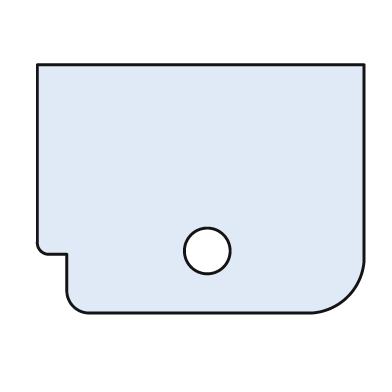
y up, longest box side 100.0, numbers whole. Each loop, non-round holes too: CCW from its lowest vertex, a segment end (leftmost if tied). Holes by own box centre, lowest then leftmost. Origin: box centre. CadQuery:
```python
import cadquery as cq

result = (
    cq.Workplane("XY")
    .moveTo(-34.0, -38.0)
    .lineTo(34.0, -38.0)
    .threePointArc((45.0, -33.0), (50.0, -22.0))
    .lineTo(50.0, 38.0)
    .lineTo(-50.0, 38.0)
    .lineTo(-50.0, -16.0)
    .threePointArc((-49.0, -19.0), (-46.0, -20.0))
    .lineTo(-41.0, -20.0)
    .lineTo(-41.0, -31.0)
    .threePointArc((-39.0, -36.0), (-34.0, -38.0))
    .close()
    .moveTo(2.0, -19.0)
    .circle(7.0)
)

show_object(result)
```